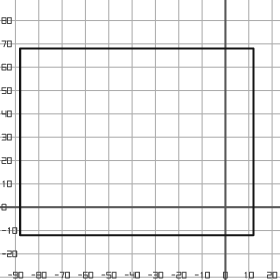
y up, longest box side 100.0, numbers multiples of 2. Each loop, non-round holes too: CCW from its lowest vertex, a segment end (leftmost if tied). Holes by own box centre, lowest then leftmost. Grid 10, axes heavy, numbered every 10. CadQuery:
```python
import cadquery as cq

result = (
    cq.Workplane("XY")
    .moveTo(-88.0, -12.0)
    .lineTo(12.0, -12.0)
    .lineTo(12.0, 68.0)
    .lineTo(-88.0, 68.0)
    .close()
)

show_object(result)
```